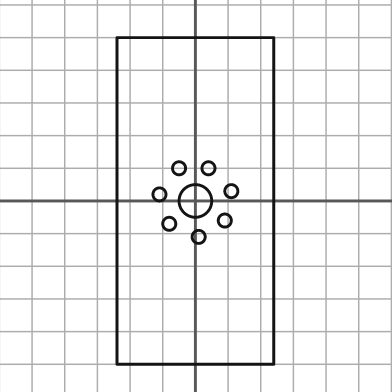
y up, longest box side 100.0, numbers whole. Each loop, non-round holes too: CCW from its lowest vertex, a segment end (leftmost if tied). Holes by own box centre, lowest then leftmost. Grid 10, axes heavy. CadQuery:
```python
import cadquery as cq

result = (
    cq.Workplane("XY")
    .moveTo(-24.0, -50.0)
    .lineTo(24.0, -50.0)
    .lineTo(24.0, 50.0)
    .lineTo(-24.0, 50.0)
    .close()
    .moveTo(1.0, -11.0)
    .circle(2.0)
    .moveTo(-8.0, -7.0)
    .circle(2.0)
    .moveTo(9.0, -6.0)
    .circle(2.0)
    .moveTo(0.0, 0.0)
    .circle(5.0)
    .moveTo(-11.0, 2.0)
    .circle(2.0)
    .moveTo(11.0, 3.0)
    .circle(2.0)
    .moveTo(-5.0, 10.0)
    .circle(2.0)
    .moveTo(4.0, 10.0)
    .circle(2.0)
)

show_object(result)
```